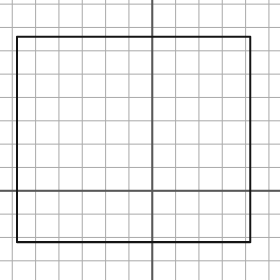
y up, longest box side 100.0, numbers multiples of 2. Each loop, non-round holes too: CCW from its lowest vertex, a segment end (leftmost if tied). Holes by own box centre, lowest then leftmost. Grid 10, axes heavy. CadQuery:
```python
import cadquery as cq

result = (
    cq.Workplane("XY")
    .moveTo(-58.0, -22.0)
    .lineTo(42.0, -22.0)
    .lineTo(42.0, 66.0)
    .lineTo(-58.0, 66.0)
    .close()
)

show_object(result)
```